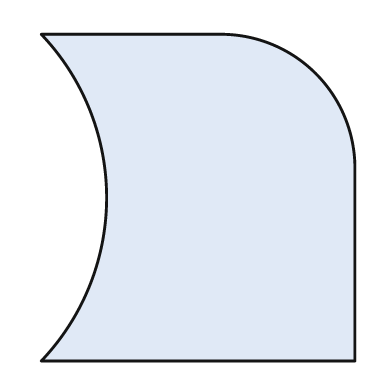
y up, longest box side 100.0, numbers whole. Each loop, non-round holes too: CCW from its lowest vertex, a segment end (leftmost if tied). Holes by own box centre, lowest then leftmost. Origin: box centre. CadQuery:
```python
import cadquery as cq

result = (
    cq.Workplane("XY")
    .moveTo(-48.0, -50.0)
    .lineTo(48.0, -50.0)
    .lineTo(48.0, 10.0)
    .threePointArc((36.0, 38.0), (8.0, 50.0))
    .lineTo(-48.0, 50.0)
    .threePointArc((-28.0, 0.0), (-48.0, -50.0))
    .close()
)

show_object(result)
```